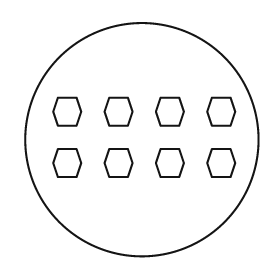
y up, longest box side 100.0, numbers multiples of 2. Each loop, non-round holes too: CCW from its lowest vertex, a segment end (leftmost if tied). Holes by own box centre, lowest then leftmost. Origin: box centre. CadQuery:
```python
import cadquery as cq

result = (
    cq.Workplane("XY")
    .moveTo(0.0, 0.0)
    .circle(50.0)
    .moveTo(-36.0, -16.0)
    .lineTo(-28.0, -16.0)
    .lineTo(-26.0, -10.0)
    .lineTo(-28.0, -4.0)
    .lineTo(-36.0, -4.0)
    .lineTo(-38.0, -10.0)
    .close()
    .moveTo(-14.0, -16.0)
    .lineTo(-6.0, -16.0)
    .lineTo(-4.0, -10.0)
    .lineTo(-6.0, -4.0)
    .lineTo(-14.0, -4.0)
    .lineTo(-16.0, -10.0)
    .close()
    .moveTo(8.0, -16.0)
    .lineTo(16.0, -16.0)
    .lineTo(18.0, -10.0)
    .lineTo(16.0, -4.0)
    .lineTo(8.0, -4.0)
    .lineTo(6.0, -10.0)
    .close()
    .moveTo(30.0, -16.0)
    .lineTo(38.0, -16.0)
    .lineTo(40.0, -10.0)
    .lineTo(38.0, -4.0)
    .lineTo(30.0, -4.0)
    .lineTo(28.0, -10.0)
    .close()
    .moveTo(-36.0, 6.0)
    .lineTo(-28.0, 6.0)
    .lineTo(-26.0, 12.0)
    .lineTo(-28.0, 18.0)
    .lineTo(-36.0, 18.0)
    .lineTo(-38.0, 12.0)
    .close()
    .moveTo(-14.0, 6.0)
    .lineTo(-6.0, 6.0)
    .lineTo(-4.0, 12.0)
    .lineTo(-6.0, 18.0)
    .lineTo(-14.0, 18.0)
    .lineTo(-16.0, 12.0)
    .close()
    .moveTo(8.0, 6.0)
    .lineTo(16.0, 6.0)
    .lineTo(18.0, 12.0)
    .lineTo(16.0, 18.0)
    .lineTo(8.0, 18.0)
    .lineTo(6.0, 12.0)
    .close()
    .moveTo(30.0, 6.0)
    .lineTo(38.0, 6.0)
    .lineTo(40.0, 12.0)
    .lineTo(38.0, 18.0)
    .lineTo(30.0, 18.0)
    .lineTo(28.0, 12.0)
    .close()
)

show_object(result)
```